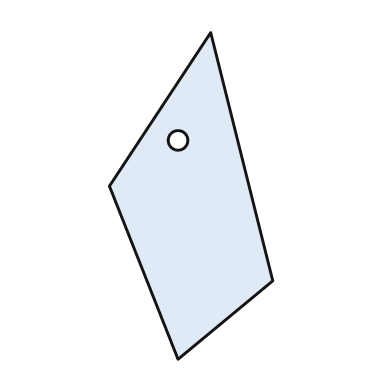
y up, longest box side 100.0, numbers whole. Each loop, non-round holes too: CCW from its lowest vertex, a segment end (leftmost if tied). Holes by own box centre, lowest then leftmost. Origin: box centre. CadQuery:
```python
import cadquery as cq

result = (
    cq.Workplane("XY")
    .moveTo(-4.0, -50.0)
    .lineTo(25.0, -26.0)
    .lineTo(6.0, 50.0)
    .lineTo(-25.0, 3.0)
    .close()
    .moveTo(-4.0, 17.0)
    .circle(3.0)
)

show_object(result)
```